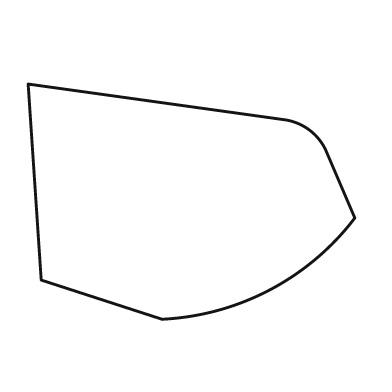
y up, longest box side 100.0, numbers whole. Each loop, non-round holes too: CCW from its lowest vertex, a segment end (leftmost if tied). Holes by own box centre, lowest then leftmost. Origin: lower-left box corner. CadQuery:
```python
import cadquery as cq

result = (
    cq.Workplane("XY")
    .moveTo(41.0, 0.0)
    .threePointArc((74.0, 9.0), (100.0, 31.0))
    .lineTo(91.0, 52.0)
    .threePointArc((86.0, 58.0), (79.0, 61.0))
    .lineTo(0.0, 72.0)
    .lineTo(4.0, 12.0)
    .close()
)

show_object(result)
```